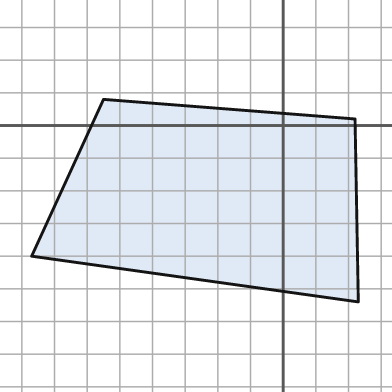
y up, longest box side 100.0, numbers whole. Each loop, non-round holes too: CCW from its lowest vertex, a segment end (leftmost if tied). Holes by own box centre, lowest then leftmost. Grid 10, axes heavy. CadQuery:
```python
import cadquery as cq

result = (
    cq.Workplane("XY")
    .moveTo(23.0, -54.0)
    .lineTo(22.0, 2.0)
    .lineTo(-55.0, 8.0)
    .lineTo(-77.0, -40.0)
    .close()
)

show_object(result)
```